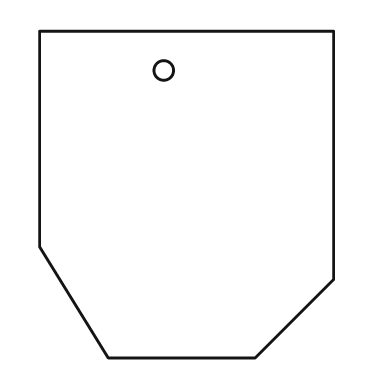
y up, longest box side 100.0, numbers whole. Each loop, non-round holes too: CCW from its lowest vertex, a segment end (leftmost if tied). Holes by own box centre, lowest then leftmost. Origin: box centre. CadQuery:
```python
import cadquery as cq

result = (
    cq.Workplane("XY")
    .moveTo(-24.0, -50.0)
    .lineTo(21.0, -50.0)
    .lineTo(45.0, -26.0)
    .lineTo(45.0, 50.0)
    .lineTo(-45.0, 50.0)
    .lineTo(-45.0, -16.0)
    .close()
    .moveTo(-7.0, 38.0)
    .circle(3.0)
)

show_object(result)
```